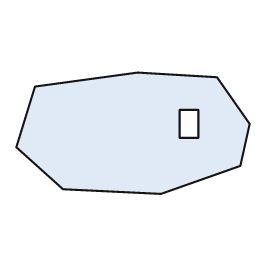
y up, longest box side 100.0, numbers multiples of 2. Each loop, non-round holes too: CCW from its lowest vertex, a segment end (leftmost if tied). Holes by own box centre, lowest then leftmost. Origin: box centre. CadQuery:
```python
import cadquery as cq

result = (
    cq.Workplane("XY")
    .moveTo(12.0, -26.0)
    .lineTo(46.0, -14.0)
    .lineTo(50.0, 4.0)
    .lineTo(36.0, 24.0)
    .lineTo(2.0, 26.0)
    .lineTo(-42.0, 20.0)
    .lineTo(-50.0, -6.0)
    .lineTo(-30.0, -24.0)
    .close()
    .moveTo(20.0, -2.0)
    .lineTo(28.0, -2.0)
    .lineTo(28.0, 10.0)
    .lineTo(20.0, 10.0)
    .close()
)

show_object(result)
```